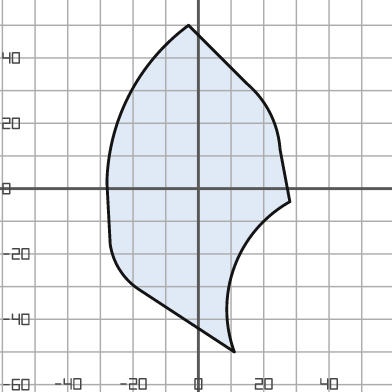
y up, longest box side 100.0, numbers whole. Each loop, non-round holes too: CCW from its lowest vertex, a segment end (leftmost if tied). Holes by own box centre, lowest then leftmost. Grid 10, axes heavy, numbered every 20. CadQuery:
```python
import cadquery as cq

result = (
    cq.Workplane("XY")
    .moveTo(11.0, -50.0)
    .threePointArc((11.0, -24.0), (28.0, -4.0))
    .lineTo(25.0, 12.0)
    .threePointArc((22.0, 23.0), (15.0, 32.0))
    .lineTo(-3.0, 50.0)
    .threePointArc((-21.0, 29.0), (-28.0, 2.0))
    .lineTo(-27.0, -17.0)
    .threePointArc((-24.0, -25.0), (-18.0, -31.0))
    .close()
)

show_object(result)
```